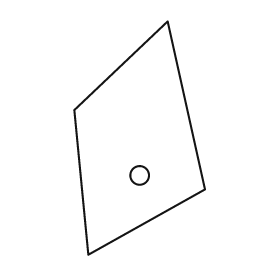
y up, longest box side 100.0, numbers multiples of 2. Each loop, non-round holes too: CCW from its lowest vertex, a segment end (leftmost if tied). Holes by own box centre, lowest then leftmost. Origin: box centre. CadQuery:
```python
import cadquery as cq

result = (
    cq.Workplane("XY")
    .moveTo(-22.0, -50.0)
    .lineTo(28.0, -22.0)
    .lineTo(12.0, 50.0)
    .lineTo(-28.0, 12.0)
    .close()
    .moveTo(0.0, -16.0)
    .circle(4.0)
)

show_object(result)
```